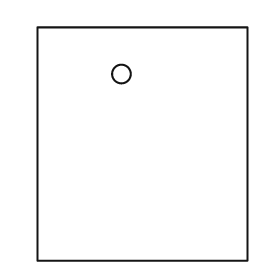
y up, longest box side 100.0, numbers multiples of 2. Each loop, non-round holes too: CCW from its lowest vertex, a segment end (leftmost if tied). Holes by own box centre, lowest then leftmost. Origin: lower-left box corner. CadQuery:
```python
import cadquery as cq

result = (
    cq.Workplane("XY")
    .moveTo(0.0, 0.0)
    .lineTo(90.0, 0.0)
    .lineTo(90.0, 100.0)
    .lineTo(0.0, 100.0)
    .close()
    .moveTo(36.0, 80.0)
    .circle(4.0)
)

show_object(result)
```